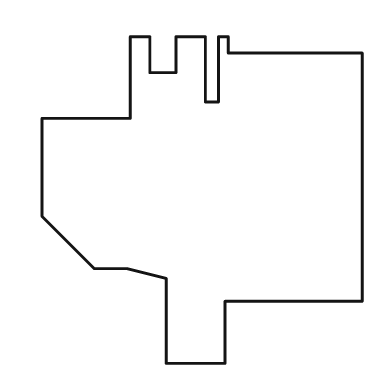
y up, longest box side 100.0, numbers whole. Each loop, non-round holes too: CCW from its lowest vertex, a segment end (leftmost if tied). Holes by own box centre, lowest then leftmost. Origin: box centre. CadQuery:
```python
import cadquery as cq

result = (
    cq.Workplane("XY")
    .moveTo(-11.0, -50.0)
    .lineTo(7.0, -50.0)
    .lineTo(7.0, -31.0)
    .lineTo(49.0, -31.0)
    .lineTo(49.0, 45.0)
    .lineTo(8.0, 45.0)
    .lineTo(8.0, 50.0)
    .lineTo(5.0, 50.0)
    .lineTo(5.0, 30.0)
    .lineTo(1.0, 30.0)
    .lineTo(1.0, 50.0)
    .lineTo(-8.0, 50.0)
    .lineTo(-8.0, 39.0)
    .lineTo(-16.0, 39.0)
    .lineTo(-16.0, 50.0)
    .lineTo(-22.0, 50.0)
    .lineTo(-22.0, 25.0)
    .lineTo(-49.0, 25.0)
    .lineTo(-49.0, -5.0)
    .lineTo(-33.0, -21.0)
    .lineTo(-23.0, -21.0)
    .lineTo(-11.0, -24.0)
    .close()
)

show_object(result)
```